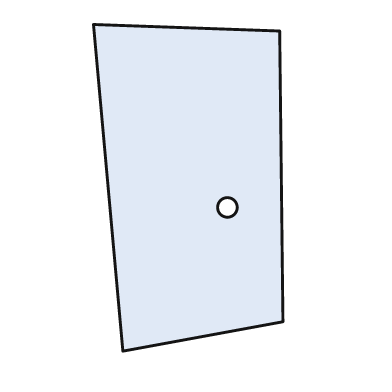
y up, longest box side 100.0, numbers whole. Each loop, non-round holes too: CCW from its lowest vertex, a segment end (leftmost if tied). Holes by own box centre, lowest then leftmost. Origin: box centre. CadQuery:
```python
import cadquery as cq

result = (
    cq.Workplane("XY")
    .moveTo(-20.0, -50.0)
    .lineTo(29.0, -41.0)
    .lineTo(28.0, 48.0)
    .lineTo(-29.0, 50.0)
    .close()
    .moveTo(12.0, -6.0)
    .circle(3.0)
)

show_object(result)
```